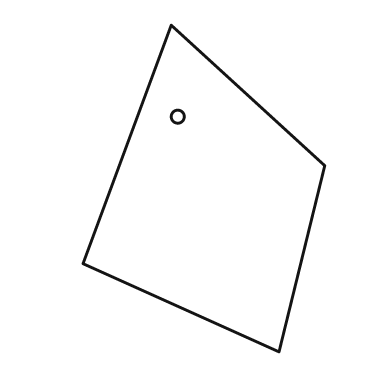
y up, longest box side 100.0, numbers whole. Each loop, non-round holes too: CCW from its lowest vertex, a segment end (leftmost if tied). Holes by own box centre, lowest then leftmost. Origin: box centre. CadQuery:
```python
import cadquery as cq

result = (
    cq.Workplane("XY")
    .moveTo(23.0, -50.0)
    .lineTo(37.0, 7.0)
    .lineTo(-10.0, 50.0)
    .lineTo(-37.0, -23.0)
    .close()
    .moveTo(-8.0, 22.0)
    .circle(2.0)
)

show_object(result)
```